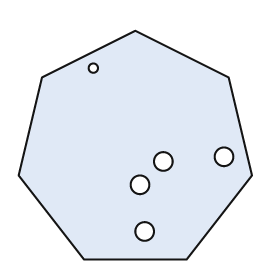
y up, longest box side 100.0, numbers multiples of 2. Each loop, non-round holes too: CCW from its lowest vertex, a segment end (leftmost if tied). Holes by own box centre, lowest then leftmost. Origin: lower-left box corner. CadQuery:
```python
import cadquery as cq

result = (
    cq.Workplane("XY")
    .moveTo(28.0, 0.0)
    .lineTo(72.0, 0.0)
    .lineTo(100.0, 36.0)
    .lineTo(90.0, 78.0)
    .lineTo(50.0, 98.0)
    .lineTo(10.0, 78.0)
    .lineTo(0.0, 36.0)
    .close()
    .moveTo(54.0, 12.0)
    .circle(4.0)
    .moveTo(52.0, 32.0)
    .circle(4.0)
    .moveTo(62.0, 42.0)
    .circle(4.0)
    .moveTo(88.0, 44.0)
    .circle(4.0)
    .moveTo(32.0, 82.0)
    .circle(2.0)
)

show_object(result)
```